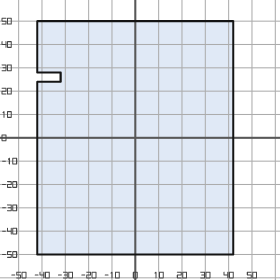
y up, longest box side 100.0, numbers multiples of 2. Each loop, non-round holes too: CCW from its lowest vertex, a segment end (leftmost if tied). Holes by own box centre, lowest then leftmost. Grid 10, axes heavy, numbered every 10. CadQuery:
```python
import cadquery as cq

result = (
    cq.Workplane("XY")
    .moveTo(-42.0, -50.0)
    .lineTo(42.0, -50.0)
    .lineTo(42.0, 50.0)
    .lineTo(-42.0, 50.0)
    .lineTo(-42.0, 28.0)
    .lineTo(-32.0, 28.0)
    .lineTo(-32.0, 24.0)
    .lineTo(-42.0, 24.0)
    .close()
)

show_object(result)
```